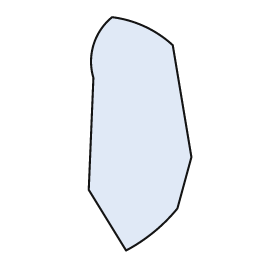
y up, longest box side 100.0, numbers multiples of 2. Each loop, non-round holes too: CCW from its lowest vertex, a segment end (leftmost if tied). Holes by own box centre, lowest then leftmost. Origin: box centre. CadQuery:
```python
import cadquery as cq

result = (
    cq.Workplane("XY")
    .moveTo(-6.0, -50.0)
    .threePointArc((6.0, -42.0), (16.0, -32.0))
    .lineTo(22.0, -10.0)
    .lineTo(14.0, 38.0)
    .threePointArc((2.0, 46.0), (-12.0, 50.0))
    .threePointArc((-20.0, 38.0), (-20.0, 24.0))
    .lineTo(-22.0, -24.0)
    .close()
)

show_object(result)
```